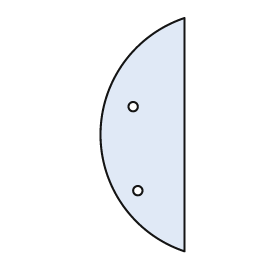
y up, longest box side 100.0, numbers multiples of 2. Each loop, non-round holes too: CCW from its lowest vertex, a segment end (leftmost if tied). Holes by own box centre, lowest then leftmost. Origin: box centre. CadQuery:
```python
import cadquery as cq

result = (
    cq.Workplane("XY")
    .moveTo(18.0, -50.0)
    .lineTo(18.0, 50.0)
    .threePointArc((-18.0, 0.0), (18.0, -50.0))
    .close()
    .moveTo(-2.0, -24.0)
    .circle(2.0)
    .moveTo(-4.0, 12.0)
    .circle(2.0)
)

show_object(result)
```